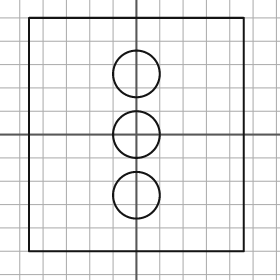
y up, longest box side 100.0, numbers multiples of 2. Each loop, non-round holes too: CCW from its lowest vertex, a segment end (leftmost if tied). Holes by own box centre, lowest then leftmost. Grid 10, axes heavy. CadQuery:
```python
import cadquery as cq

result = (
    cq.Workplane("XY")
    .moveTo(-46.0, -50.0)
    .lineTo(46.0, -50.0)
    .lineTo(46.0, 50.0)
    .lineTo(-46.0, 50.0)
    .close()
    .moveTo(0.0, -26.0)
    .circle(10.0)
    .moveTo(0.0, 0.0)
    .circle(10.0)
    .moveTo(0.0, 26.0)
    .circle(10.0)
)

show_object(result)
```